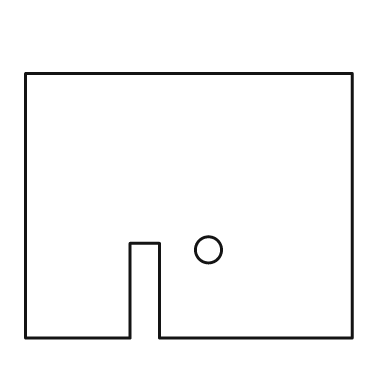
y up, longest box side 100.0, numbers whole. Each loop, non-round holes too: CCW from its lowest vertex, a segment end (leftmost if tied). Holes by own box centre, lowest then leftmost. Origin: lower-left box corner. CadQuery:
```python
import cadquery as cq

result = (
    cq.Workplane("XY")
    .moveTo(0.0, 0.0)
    .lineTo(32.0, 0.0)
    .lineTo(32.0, 29.0)
    .lineTo(41.0, 29.0)
    .lineTo(41.0, 0.0)
    .lineTo(100.0, 0.0)
    .lineTo(100.0, 81.0)
    .lineTo(0.0, 81.0)
    .close()
    .moveTo(56.0, 27.0)
    .circle(4.0)
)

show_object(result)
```